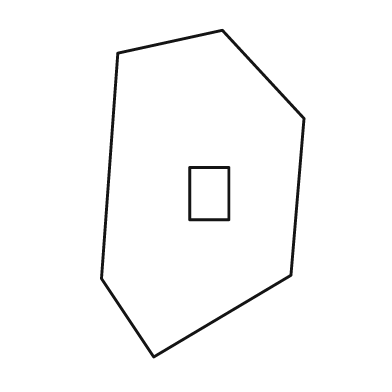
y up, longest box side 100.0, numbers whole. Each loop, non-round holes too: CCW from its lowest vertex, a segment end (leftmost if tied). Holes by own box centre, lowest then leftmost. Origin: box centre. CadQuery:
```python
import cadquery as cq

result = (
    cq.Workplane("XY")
    .moveTo(-15.0, -50.0)
    .lineTo(27.0, -25.0)
    .lineTo(31.0, 23.0)
    .lineTo(6.0, 50.0)
    .lineTo(-26.0, 43.0)
    .lineTo(-31.0, -26.0)
    .close()
    .moveTo(-4.0, -8.0)
    .lineTo(8.0, -8.0)
    .lineTo(8.0, 8.0)
    .lineTo(-4.0, 8.0)
    .close()
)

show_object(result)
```